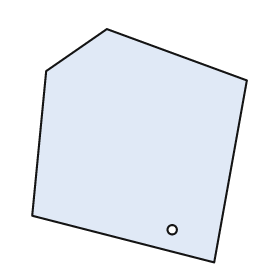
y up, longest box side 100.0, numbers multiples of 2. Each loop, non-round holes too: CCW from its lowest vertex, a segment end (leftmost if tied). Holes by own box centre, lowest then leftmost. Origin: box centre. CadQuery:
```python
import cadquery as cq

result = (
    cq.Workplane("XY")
    .moveTo(32.0, -50.0)
    .lineTo(46.0, 28.0)
    .lineTo(-14.0, 50.0)
    .lineTo(-40.0, 32.0)
    .lineTo(-46.0, -30.0)
    .close()
    .moveTo(14.0, -36.0)
    .circle(2.0)
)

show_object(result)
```